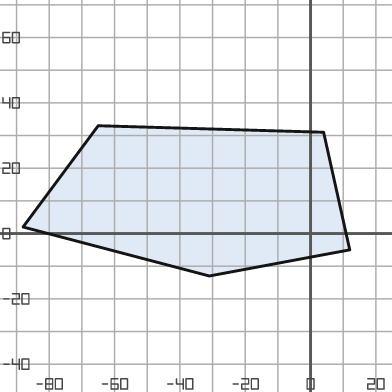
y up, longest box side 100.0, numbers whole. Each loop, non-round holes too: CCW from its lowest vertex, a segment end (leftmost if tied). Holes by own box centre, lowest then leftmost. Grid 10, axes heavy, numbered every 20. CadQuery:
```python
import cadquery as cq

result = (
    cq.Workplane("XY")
    .moveTo(-31.0, -13.0)
    .lineTo(12.0, -5.0)
    .lineTo(4.0, 31.0)
    .lineTo(-65.0, 33.0)
    .lineTo(-88.0, 2.0)
    .close()
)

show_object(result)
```